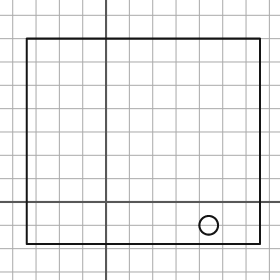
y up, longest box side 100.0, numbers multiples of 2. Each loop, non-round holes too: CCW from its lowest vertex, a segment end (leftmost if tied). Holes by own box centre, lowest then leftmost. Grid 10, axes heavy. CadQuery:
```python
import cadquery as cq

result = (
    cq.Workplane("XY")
    .moveTo(-34.0, -18.0)
    .lineTo(66.0, -18.0)
    .lineTo(66.0, 70.0)
    .lineTo(-34.0, 70.0)
    .close()
    .moveTo(44.0, -10.0)
    .circle(4.0)
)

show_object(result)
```